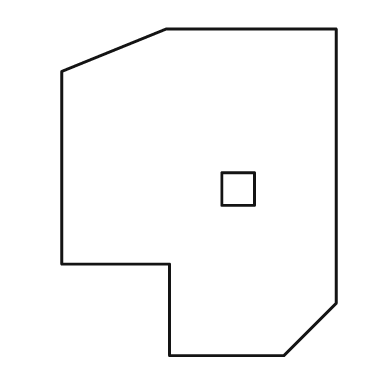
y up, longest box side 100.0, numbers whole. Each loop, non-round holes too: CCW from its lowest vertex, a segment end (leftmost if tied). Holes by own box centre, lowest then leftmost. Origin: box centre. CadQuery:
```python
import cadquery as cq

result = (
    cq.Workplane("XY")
    .moveTo(-9.0, -50.0)
    .lineTo(26.0, -50.0)
    .lineTo(42.0, -34.0)
    .lineTo(42.0, 50.0)
    .lineTo(-10.0, 50.0)
    .lineTo(-42.0, 37.0)
    .lineTo(-42.0, -22.0)
    .lineTo(-9.0, -22.0)
    .close()
    .moveTo(7.0, -4.0)
    .lineTo(17.0, -4.0)
    .lineTo(17.0, 6.0)
    .lineTo(7.0, 6.0)
    .close()
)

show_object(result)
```